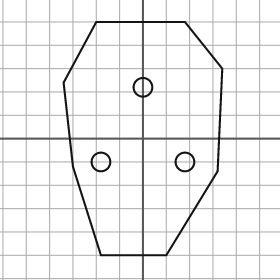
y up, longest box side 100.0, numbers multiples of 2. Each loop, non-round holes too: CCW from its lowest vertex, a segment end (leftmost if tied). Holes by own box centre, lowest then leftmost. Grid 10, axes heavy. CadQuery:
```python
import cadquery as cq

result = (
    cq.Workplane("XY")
    .moveTo(-18.0, -50.0)
    .lineTo(10.0, -50.0)
    .lineTo(32.0, -14.0)
    .lineTo(34.0, 30.0)
    .lineTo(18.0, 50.0)
    .lineTo(-20.0, 50.0)
    .lineTo(-34.0, 24.0)
    .lineTo(-30.0, -12.0)
    .close()
    .moveTo(-18.0, -10.0)
    .circle(4.0)
    .moveTo(18.0, -10.0)
    .circle(4.0)
    .moveTo(0.0, 22.0)
    .circle(4.0)
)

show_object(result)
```